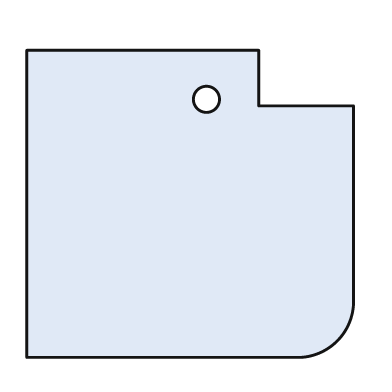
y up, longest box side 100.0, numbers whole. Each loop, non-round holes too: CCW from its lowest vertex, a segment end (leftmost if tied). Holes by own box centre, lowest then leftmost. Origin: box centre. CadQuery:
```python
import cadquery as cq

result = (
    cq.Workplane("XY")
    .moveTo(-50.0, -47.0)
    .lineTo(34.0, -47.0)
    .threePointArc((45.0, -42.0), (50.0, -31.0))
    .lineTo(50.0, 30.0)
    .lineTo(21.0, 30.0)
    .lineTo(21.0, 47.0)
    .lineTo(-50.0, 47.0)
    .close()
    .moveTo(5.0, 32.0)
    .circle(4.0)
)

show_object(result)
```